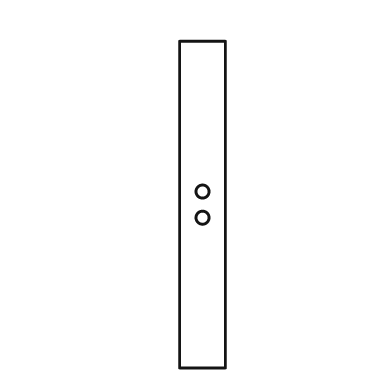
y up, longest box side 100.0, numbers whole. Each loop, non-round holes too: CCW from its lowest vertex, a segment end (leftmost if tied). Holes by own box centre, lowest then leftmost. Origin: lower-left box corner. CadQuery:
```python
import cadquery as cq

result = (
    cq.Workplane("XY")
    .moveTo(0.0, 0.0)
    .lineTo(14.0, 0.0)
    .lineTo(14.0, 100.0)
    .lineTo(0.0, 100.0)
    .close()
    .moveTo(7.0, 46.0)
    .circle(2.0)
    .moveTo(7.0, 54.0)
    .circle(2.0)
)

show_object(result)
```